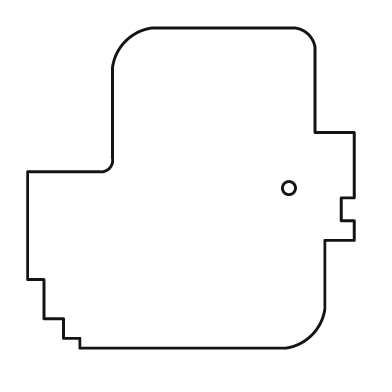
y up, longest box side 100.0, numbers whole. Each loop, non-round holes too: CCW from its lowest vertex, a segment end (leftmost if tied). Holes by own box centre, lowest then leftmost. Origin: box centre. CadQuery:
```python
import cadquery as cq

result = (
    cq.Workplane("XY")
    .moveTo(-34.0, -49.0)
    .lineTo(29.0, -49.0)
    .threePointArc((37.0, -45.0), (41.0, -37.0))
    .lineTo(41.0, -16.0)
    .lineTo(50.0, -16.0)
    .lineTo(50.0, -10.0)
    .lineTo(46.0, -10.0)
    .lineTo(46.0, -3.0)
    .lineTo(50.0, -3.0)
    .lineTo(50.0, 17.0)
    .lineTo(38.0, 17.0)
    .lineTo(38.0, 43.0)
    .threePointArc((36.0, 47.0), (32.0, 49.0))
    .lineTo(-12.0, 49.0)
    .threePointArc((-20.0, 45.0), (-24.0, 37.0))
    .lineTo(-24.0, 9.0)
    .threePointArc((-25.0, 6.0), (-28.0, 5.0))
    .lineTo(-50.0, 5.0)
    .lineTo(-50.0, -28.0)
    .lineTo(-45.0, -28.0)
    .lineTo(-45.0, -40.0)
    .lineTo(-39.0, -40.0)
    .lineTo(-39.0, -46.0)
    .lineTo(-34.0, -46.0)
    .close()
    .moveTo(30.0, 0.0)
    .circle(2.0)
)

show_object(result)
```